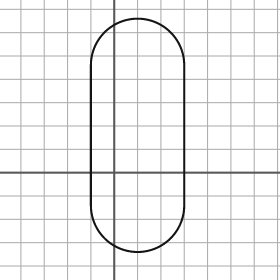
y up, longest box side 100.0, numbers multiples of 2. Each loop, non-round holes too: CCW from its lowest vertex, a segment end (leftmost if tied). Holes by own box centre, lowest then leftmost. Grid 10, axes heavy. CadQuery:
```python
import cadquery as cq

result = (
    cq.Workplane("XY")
    .moveTo(-10.0, -14.0)
    .threePointArc((10.0, -34.0), (30.0, -14.0))
    .lineTo(30.0, 46.0)
    .threePointArc((10.0, 66.0), (-10.0, 46.0))
    .close()
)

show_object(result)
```